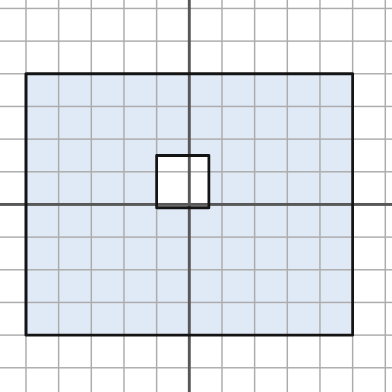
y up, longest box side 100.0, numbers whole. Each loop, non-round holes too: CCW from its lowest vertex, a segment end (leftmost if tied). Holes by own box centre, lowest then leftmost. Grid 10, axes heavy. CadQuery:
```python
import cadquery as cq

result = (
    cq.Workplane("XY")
    .moveTo(-50.0, -40.0)
    .lineTo(50.0, -40.0)
    .lineTo(50.0, 40.0)
    .lineTo(-50.0, 40.0)
    .close()
    .moveTo(-10.0, -1.0)
    .lineTo(6.0, -1.0)
    .lineTo(6.0, 15.0)
    .lineTo(-10.0, 15.0)
    .close()
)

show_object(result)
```